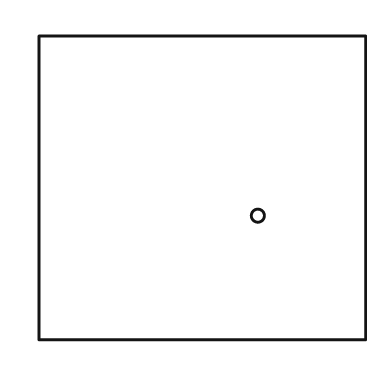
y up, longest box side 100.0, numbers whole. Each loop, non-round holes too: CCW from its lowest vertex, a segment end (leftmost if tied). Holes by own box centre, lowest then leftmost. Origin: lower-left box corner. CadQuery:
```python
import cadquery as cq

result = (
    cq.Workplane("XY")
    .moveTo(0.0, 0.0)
    .lineTo(100.0, 0.0)
    .lineTo(100.0, 93.0)
    .lineTo(0.0, 93.0)
    .close()
    .moveTo(67.0, 38.0)
    .circle(2.0)
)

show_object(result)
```